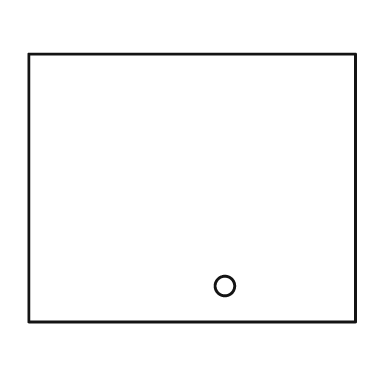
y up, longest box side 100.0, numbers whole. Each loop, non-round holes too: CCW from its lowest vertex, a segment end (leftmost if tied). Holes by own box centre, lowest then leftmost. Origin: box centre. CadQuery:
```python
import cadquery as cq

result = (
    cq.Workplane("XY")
    .moveTo(-50.0, -41.0)
    .lineTo(50.0, -41.0)
    .lineTo(50.0, 41.0)
    .lineTo(-50.0, 41.0)
    .close()
    .moveTo(10.0, -30.0)
    .circle(3.0)
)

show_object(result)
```